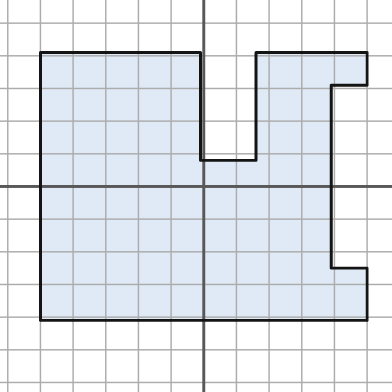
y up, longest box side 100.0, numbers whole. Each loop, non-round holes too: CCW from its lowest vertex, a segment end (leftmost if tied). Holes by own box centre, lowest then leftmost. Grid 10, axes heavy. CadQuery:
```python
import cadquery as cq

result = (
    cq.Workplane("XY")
    .moveTo(-50.0, -41.0)
    .lineTo(50.0, -41.0)
    .lineTo(50.0, -25.0)
    .lineTo(39.0, -25.0)
    .lineTo(39.0, 31.0)
    .lineTo(50.0, 31.0)
    .lineTo(50.0, 41.0)
    .lineTo(16.0, 41.0)
    .lineTo(16.0, 8.0)
    .lineTo(-1.0, 8.0)
    .lineTo(-1.0, 41.0)
    .lineTo(-50.0, 41.0)
    .close()
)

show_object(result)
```